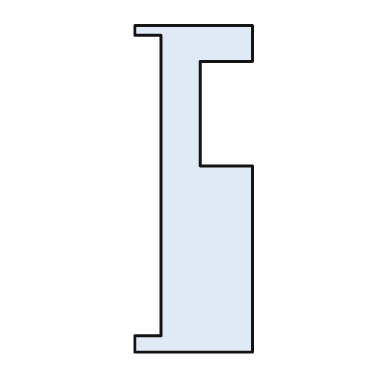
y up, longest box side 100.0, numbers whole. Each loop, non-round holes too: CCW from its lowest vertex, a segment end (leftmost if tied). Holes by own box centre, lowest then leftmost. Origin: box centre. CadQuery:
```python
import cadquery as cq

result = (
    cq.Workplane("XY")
    .moveTo(-18.0, -50.0)
    .lineTo(18.0, -50.0)
    .lineTo(18.0, 7.0)
    .lineTo(2.0, 7.0)
    .lineTo(2.0, 39.0)
    .lineTo(18.0, 39.0)
    .lineTo(18.0, 50.0)
    .lineTo(-18.0, 50.0)
    .lineTo(-18.0, 47.0)
    .lineTo(-10.0, 47.0)
    .lineTo(-10.0, -45.0)
    .lineTo(-18.0, -45.0)
    .close()
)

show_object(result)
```